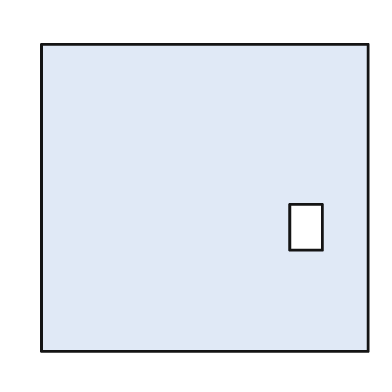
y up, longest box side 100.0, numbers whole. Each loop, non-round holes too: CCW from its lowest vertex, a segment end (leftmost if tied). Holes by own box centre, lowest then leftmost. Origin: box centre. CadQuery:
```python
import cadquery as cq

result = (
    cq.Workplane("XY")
    .moveTo(-50.0, -47.0)
    .lineTo(50.0, -47.0)
    .lineTo(50.0, 47.0)
    .lineTo(-50.0, 47.0)
    .close()
    .moveTo(26.0, -16.0)
    .lineTo(36.0, -16.0)
    .lineTo(36.0, -2.0)
    .lineTo(26.0, -2.0)
    .close()
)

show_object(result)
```